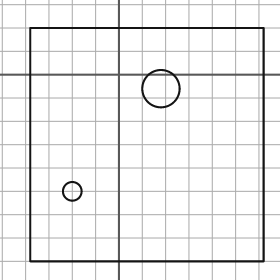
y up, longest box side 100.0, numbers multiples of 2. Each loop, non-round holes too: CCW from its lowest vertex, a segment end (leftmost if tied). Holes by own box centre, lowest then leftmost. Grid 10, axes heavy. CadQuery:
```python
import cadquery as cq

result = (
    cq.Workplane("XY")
    .moveTo(-38.0, -80.0)
    .lineTo(62.0, -80.0)
    .lineTo(62.0, 20.0)
    .lineTo(-38.0, 20.0)
    .close()
    .moveTo(-20.0, -50.0)
    .circle(4.0)
    .moveTo(18.0, -6.0)
    .circle(8.0)
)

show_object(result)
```